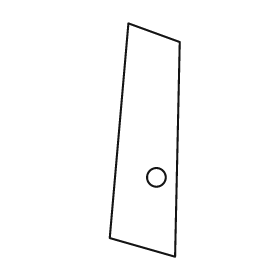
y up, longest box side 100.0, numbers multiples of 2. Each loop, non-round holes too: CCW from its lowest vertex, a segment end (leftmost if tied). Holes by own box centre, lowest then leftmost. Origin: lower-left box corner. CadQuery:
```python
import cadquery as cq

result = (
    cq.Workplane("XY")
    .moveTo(28.0, 0.0)
    .lineTo(30.0, 92.0)
    .lineTo(8.0, 100.0)
    .lineTo(0.0, 8.0)
    .close()
    .moveTo(20.0, 34.0)
    .circle(4.0)
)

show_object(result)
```